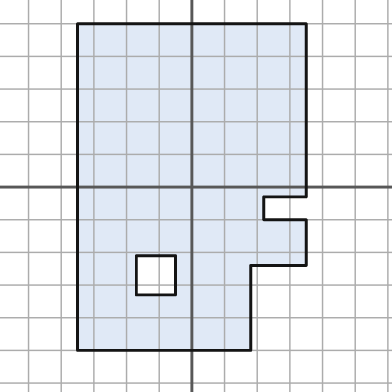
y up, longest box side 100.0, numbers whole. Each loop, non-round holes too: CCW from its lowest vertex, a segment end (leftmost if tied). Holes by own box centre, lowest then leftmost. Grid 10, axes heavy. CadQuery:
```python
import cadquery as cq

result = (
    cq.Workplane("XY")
    .moveTo(-35.0, -50.0)
    .lineTo(18.0, -50.0)
    .lineTo(18.0, -24.0)
    .lineTo(35.0, -24.0)
    .lineTo(35.0, -10.0)
    .lineTo(22.0, -10.0)
    .lineTo(22.0, -3.0)
    .lineTo(35.0, -3.0)
    .lineTo(35.0, 50.0)
    .lineTo(-35.0, 50.0)
    .close()
    .moveTo(-17.0, -33.0)
    .lineTo(-5.0, -33.0)
    .lineTo(-5.0, -21.0)
    .lineTo(-17.0, -21.0)
    .close()
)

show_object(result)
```